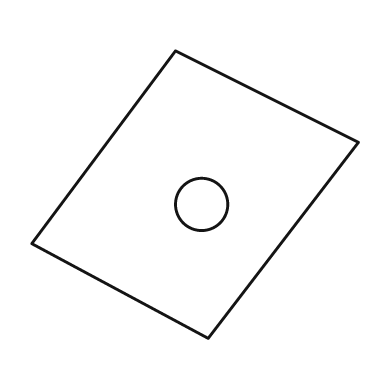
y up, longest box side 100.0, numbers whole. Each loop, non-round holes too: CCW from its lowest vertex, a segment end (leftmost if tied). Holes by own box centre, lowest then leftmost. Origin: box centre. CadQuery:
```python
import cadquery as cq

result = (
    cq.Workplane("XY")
    .moveTo(4.0, -44.0)
    .lineTo(50.0, 16.0)
    .lineTo(-6.0, 44.0)
    .lineTo(-50.0, -15.0)
    .close()
    .moveTo(2.0, -3.0)
    .circle(8.0)
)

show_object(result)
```